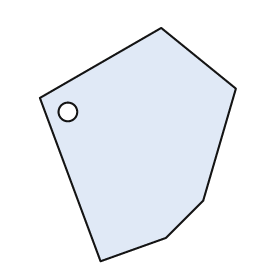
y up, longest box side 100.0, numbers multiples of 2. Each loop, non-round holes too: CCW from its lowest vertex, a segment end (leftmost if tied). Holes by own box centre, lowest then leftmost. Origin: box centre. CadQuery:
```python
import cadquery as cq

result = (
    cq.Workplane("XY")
    .moveTo(-16.0, -50.0)
    .lineTo(12.0, -40.0)
    .lineTo(28.0, -24.0)
    .lineTo(42.0, 24.0)
    .lineTo(10.0, 50.0)
    .lineTo(-42.0, 20.0)
    .close()
    .moveTo(-30.0, 14.0)
    .circle(4.0)
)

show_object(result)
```